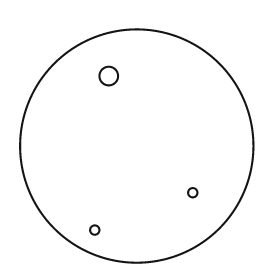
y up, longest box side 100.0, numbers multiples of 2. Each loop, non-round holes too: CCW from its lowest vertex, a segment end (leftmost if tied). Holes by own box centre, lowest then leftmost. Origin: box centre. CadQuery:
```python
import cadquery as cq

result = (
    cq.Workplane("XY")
    .moveTo(0.0, 0.0)
    .circle(50.0)
    .moveTo(-18.0, -36.0)
    .circle(2.0)
    .moveTo(24.0, -20.0)
    .circle(2.0)
    .moveTo(-12.0, 30.0)
    .circle(4.0)
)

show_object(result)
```